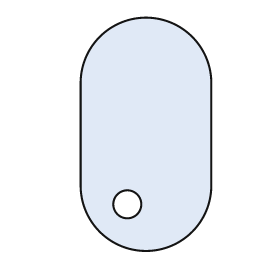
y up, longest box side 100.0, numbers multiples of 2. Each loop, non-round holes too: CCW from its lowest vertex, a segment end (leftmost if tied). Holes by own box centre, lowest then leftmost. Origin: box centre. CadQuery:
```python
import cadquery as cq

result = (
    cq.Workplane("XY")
    .moveTo(-28.0, -22.0)
    .threePointArc((0.0, -50.0), (28.0, -22.0))
    .lineTo(28.0, 22.0)
    .threePointArc((0.0, 50.0), (-28.0, 22.0))
    .close()
    .moveTo(-8.0, -30.0)
    .circle(6.0)
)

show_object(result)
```